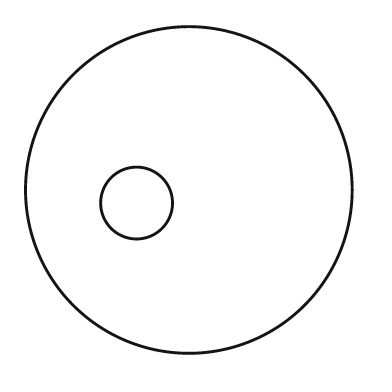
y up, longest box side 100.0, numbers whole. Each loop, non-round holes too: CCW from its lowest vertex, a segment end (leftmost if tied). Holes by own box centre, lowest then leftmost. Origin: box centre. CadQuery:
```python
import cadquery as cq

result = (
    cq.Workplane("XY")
    .moveTo(0.0, 0.0)
    .circle(50.0)
    .moveTo(-16.0, -4.0)
    .circle(11.0)
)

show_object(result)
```